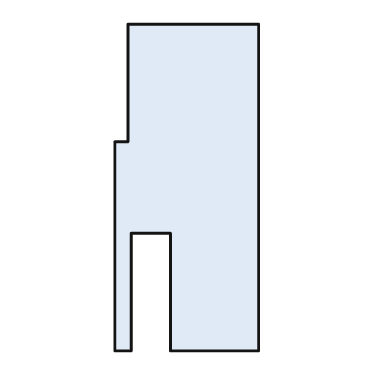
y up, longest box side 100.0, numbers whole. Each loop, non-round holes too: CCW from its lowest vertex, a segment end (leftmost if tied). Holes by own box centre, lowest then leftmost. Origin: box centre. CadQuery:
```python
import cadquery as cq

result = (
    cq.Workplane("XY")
    .moveTo(-22.0, -50.0)
    .lineTo(-17.0, -50.0)
    .lineTo(-17.0, -14.0)
    .lineTo(-5.0, -14.0)
    .lineTo(-5.0, -50.0)
    .lineTo(22.0, -50.0)
    .lineTo(22.0, 50.0)
    .lineTo(-18.0, 50.0)
    .lineTo(-18.0, 14.0)
    .lineTo(-22.0, 14.0)
    .close()
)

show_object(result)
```